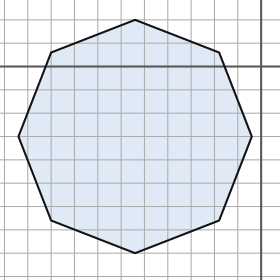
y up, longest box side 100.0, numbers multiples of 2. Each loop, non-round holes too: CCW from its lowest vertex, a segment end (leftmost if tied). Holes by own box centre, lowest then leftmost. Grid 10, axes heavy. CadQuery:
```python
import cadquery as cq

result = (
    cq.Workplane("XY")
    .moveTo(-54.0, -80.0)
    .lineTo(-18.0, -66.0)
    .lineTo(-4.0, -30.0)
    .lineTo(-18.0, 6.0)
    .lineTo(-54.0, 20.0)
    .lineTo(-90.0, 6.0)
    .lineTo(-104.0, -30.0)
    .lineTo(-90.0, -66.0)
    .close()
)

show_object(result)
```